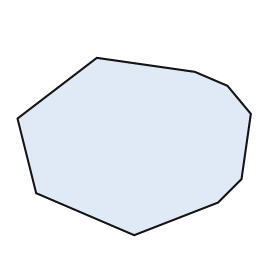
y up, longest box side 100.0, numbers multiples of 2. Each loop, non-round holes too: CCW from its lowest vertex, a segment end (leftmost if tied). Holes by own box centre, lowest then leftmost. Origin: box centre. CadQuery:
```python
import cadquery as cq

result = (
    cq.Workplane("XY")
    .moveTo(0.0, -38.0)
    .lineTo(36.0, -24.0)
    .lineTo(46.0, -14.0)
    .lineTo(50.0, 14.0)
    .lineTo(40.0, 26.0)
    .lineTo(26.0, 32.0)
    .lineTo(-16.0, 38.0)
    .lineTo(-50.0, 12.0)
    .lineTo(-42.0, -20.0)
    .close()
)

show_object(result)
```